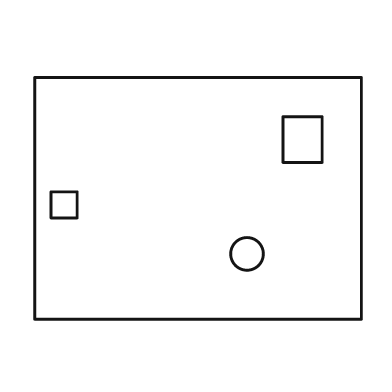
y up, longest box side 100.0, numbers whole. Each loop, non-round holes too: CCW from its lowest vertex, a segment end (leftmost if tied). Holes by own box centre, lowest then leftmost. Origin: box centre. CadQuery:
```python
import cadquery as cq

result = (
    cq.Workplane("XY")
    .moveTo(-50.0, -37.0)
    .lineTo(50.0, -37.0)
    .lineTo(50.0, 37.0)
    .lineTo(-50.0, 37.0)
    .close()
    .moveTo(15.0, -17.0)
    .circle(5.0)
    .moveTo(-45.0, -6.0)
    .lineTo(-37.0, -6.0)
    .lineTo(-37.0, 2.0)
    .lineTo(-45.0, 2.0)
    .close()
    .moveTo(26.0, 11.0)
    .lineTo(38.0, 11.0)
    .lineTo(38.0, 25.0)
    .lineTo(26.0, 25.0)
    .close()
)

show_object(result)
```